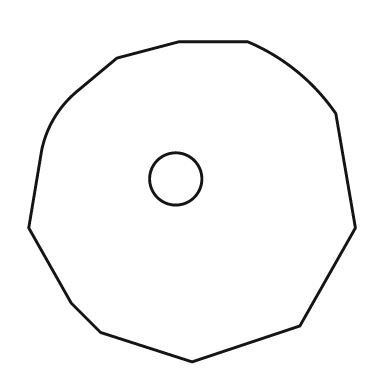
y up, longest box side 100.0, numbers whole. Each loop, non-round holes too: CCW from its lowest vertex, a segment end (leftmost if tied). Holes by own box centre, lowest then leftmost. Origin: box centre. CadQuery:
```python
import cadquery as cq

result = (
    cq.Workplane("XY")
    .moveTo(0.0, -49.0)
    .lineTo(33.0, -38.0)
    .lineTo(50.0, -8.0)
    .lineTo(44.0, 27.0)
    .threePointArc((32.0, 40.0), (17.0, 49.0))
    .lineTo(-4.0, 49.0)
    .lineTo(-23.0, 44.0)
    .lineTo(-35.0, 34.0)
    .threePointArc((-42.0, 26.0), (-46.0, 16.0))
    .lineTo(-50.0, -8.0)
    .lineTo(-37.0, -31.0)
    .lineTo(-28.0, -40.0)
    .close()
    .moveTo(-5.0, 7.0)
    .circle(8.0)
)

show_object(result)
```